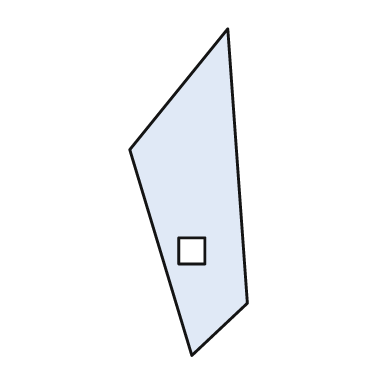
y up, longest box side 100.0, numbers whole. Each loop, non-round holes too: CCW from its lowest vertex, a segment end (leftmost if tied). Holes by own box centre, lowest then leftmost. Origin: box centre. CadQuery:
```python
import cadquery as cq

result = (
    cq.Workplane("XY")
    .moveTo(1.0, -50.0)
    .lineTo(18.0, -34.0)
    .lineTo(12.0, 50.0)
    .lineTo(-18.0, 13.0)
    .close()
    .moveTo(-3.0, -22.0)
    .lineTo(5.0, -22.0)
    .lineTo(5.0, -14.0)
    .lineTo(-3.0, -14.0)
    .close()
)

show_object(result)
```